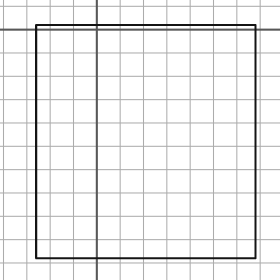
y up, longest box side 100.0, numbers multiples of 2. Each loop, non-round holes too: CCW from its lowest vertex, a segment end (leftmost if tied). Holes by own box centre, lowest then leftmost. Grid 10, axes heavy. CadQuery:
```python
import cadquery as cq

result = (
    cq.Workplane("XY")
    .moveTo(-26.0, -98.0)
    .lineTo(68.0, -98.0)
    .lineTo(68.0, 2.0)
    .lineTo(-26.0, 2.0)
    .close()
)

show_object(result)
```